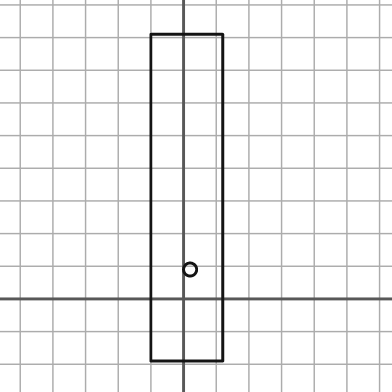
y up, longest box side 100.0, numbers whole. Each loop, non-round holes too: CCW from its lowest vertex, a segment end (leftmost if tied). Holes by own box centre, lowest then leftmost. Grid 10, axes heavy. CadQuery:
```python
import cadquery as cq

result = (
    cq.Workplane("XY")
    .moveTo(-10.0, -19.0)
    .lineTo(12.0, -19.0)
    .lineTo(12.0, 81.0)
    .lineTo(-10.0, 81.0)
    .close()
    .moveTo(2.0, 9.0)
    .circle(2.0)
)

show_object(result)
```